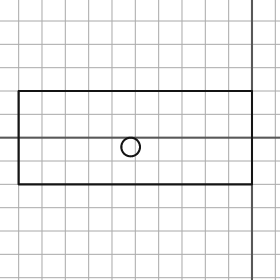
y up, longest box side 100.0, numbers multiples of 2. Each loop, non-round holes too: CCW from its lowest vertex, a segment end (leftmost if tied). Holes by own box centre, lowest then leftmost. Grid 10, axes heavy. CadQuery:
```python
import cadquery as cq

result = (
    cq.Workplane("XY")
    .moveTo(-100.0, -20.0)
    .lineTo(0.0, -20.0)
    .lineTo(0.0, 20.0)
    .lineTo(-100.0, 20.0)
    .close()
    .moveTo(-52.0, -4.0)
    .circle(4.0)
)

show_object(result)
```